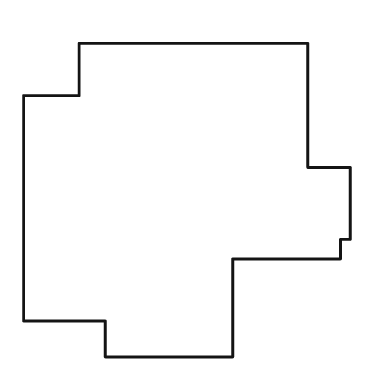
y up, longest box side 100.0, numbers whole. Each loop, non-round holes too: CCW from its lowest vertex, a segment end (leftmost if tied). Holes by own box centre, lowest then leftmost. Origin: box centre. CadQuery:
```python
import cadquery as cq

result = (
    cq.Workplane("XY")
    .moveTo(-25.0, -48.0)
    .lineTo(14.0, -48.0)
    .lineTo(14.0, -18.0)
    .lineTo(47.0, -18.0)
    .lineTo(47.0, -12.0)
    .lineTo(50.0, -12.0)
    .lineTo(50.0, 10.0)
    .lineTo(37.0, 10.0)
    .lineTo(37.0, 48.0)
    .lineTo(-33.0, 48.0)
    .lineTo(-33.0, 32.0)
    .lineTo(-50.0, 32.0)
    .lineTo(-50.0, -37.0)
    .lineTo(-25.0, -37.0)
    .close()
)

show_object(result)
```